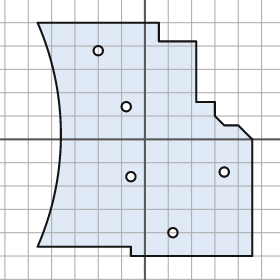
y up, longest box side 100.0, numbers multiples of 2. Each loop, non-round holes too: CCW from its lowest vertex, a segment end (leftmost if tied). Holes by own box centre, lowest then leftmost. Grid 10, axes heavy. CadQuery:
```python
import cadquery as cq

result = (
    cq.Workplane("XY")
    .moveTo(-6.0, -50.0)
    .lineTo(46.0, -50.0)
    .lineTo(46.0, 0.0)
    .lineTo(40.0, 6.0)
    .lineTo(34.0, 6.0)
    .lineTo(30.0, 10.0)
    .lineTo(30.0, 16.0)
    .lineTo(22.0, 16.0)
    .lineTo(22.0, 42.0)
    .lineTo(6.0, 42.0)
    .lineTo(6.0, 50.0)
    .lineTo(-46.0, 50.0)
    .threePointArc((-36.0, 2.0), (-46.0, -46.0))
    .lineTo(-6.0, -46.0)
    .close()
    .moveTo(12.0, -40.0)
    .circle(2.0)
    .moveTo(-6.0, -16.0)
    .circle(2.0)
    .moveTo(34.0, -14.0)
    .circle(2.0)
    .moveTo(-8.0, 14.0)
    .circle(2.0)
    .moveTo(-20.0, 38.0)
    .circle(2.0)
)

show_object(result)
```